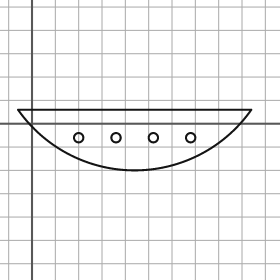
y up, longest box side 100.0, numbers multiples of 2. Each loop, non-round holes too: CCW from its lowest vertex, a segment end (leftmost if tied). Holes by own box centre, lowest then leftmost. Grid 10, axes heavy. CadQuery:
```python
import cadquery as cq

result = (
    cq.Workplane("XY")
    .moveTo(-6.0, 6.0)
    .threePointArc((44.0, -20.0), (94.0, 6.0))
    .close()
    .moveTo(20.0, -6.0)
    .circle(2.0)
    .moveTo(36.0, -6.0)
    .circle(2.0)
    .moveTo(52.0, -6.0)
    .circle(2.0)
    .moveTo(68.0, -6.0)
    .circle(2.0)
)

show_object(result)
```